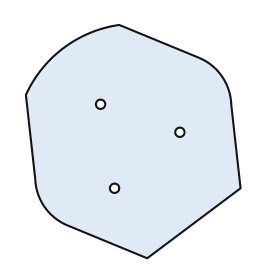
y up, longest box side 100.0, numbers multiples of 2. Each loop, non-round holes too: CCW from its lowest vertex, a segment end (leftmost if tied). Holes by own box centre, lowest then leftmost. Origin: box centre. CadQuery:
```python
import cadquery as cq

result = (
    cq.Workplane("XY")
    .moveTo(6.0, -50.0)
    .lineTo(46.0, -20.0)
    .lineTo(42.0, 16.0)
    .threePointArc((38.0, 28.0), (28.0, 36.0))
    .lineTo(-6.0, 50.0)
    .threePointArc((-30.0, 40.0), (-46.0, 20.0))
    .lineTo(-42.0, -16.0)
    .threePointArc((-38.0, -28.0), (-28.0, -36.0))
    .close()
    .moveTo(-8.0, -20.0)
    .circle(2.0)
    .moveTo(20.0, 4.0)
    .circle(2.0)
    .moveTo(-14.0, 16.0)
    .circle(2.0)
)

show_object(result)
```